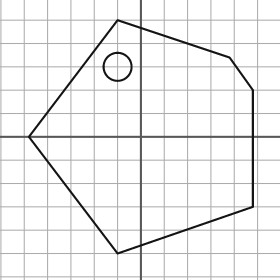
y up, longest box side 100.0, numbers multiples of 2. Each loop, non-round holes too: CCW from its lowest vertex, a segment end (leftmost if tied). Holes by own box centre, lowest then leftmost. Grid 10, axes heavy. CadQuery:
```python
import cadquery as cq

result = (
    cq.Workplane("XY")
    .moveTo(-10.0, -50.0)
    .lineTo(48.0, -30.0)
    .lineTo(48.0, 20.0)
    .lineTo(38.0, 34.0)
    .lineTo(-10.0, 50.0)
    .lineTo(-48.0, 0.0)
    .close()
    .moveTo(-10.0, 30.0)
    .circle(6.0)
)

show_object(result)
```